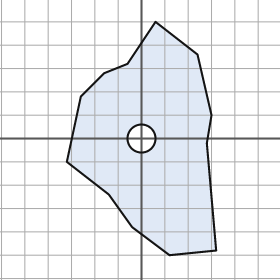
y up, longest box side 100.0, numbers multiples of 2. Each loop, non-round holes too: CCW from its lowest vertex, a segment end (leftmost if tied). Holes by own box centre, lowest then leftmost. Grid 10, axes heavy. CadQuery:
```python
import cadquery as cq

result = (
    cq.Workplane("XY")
    .moveTo(12.0, -50.0)
    .lineTo(32.0, -48.0)
    .lineTo(28.0, -2.0)
    .lineTo(30.0, 10.0)
    .lineTo(24.0, 36.0)
    .lineTo(6.0, 50.0)
    .lineTo(-6.0, 32.0)
    .lineTo(-16.0, 28.0)
    .lineTo(-26.0, 18.0)
    .lineTo(-32.0, -10.0)
    .lineTo(-14.0, -24.0)
    .lineTo(-4.0, -38.0)
    .close()
    .moveTo(0.0, 0.0)
    .circle(6.0)
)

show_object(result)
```